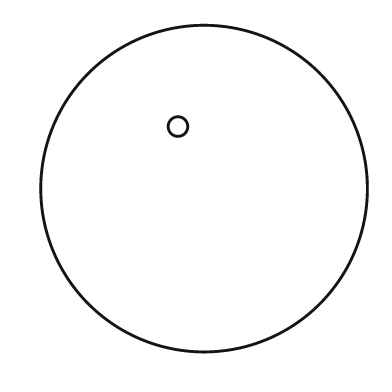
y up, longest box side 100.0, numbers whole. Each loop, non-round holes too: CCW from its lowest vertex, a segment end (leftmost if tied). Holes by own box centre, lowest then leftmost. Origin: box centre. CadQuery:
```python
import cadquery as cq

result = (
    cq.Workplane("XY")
    .moveTo(0.0, 0.0)
    .circle(50.0)
    .moveTo(-8.0, 19.0)
    .circle(3.0)
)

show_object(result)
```